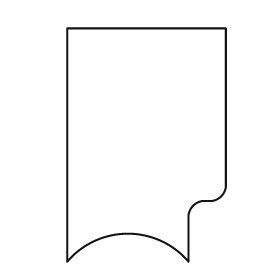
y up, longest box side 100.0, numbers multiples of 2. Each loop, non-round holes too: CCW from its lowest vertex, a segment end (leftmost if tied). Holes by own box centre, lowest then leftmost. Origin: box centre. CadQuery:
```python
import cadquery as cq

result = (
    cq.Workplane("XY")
    .moveTo(-34.0, -50.0)
    .threePointArc((-8.0, -38.0), (18.0, -50.0))
    .lineTo(18.0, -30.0)
    .threePointArc((20.0, -26.0), (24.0, -24.0))
    .lineTo(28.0, -24.0)
    .threePointArc((32.0, -22.0), (34.0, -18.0))
    .lineTo(34.0, 50.0)
    .lineTo(-34.0, 50.0)
    .close()
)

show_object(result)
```